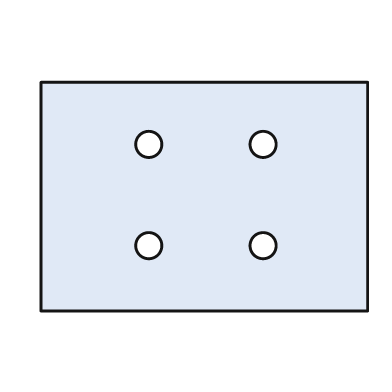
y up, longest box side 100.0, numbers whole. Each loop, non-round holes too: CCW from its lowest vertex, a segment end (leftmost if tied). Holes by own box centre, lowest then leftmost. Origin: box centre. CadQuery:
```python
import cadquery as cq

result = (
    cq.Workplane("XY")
    .moveTo(-50.0, -35.0)
    .lineTo(50.0, -35.0)
    .lineTo(50.0, 35.0)
    .lineTo(-50.0, 35.0)
    .close()
    .moveTo(-17.0, -15.0)
    .circle(4.0)
    .moveTo(18.0, -15.0)
    .circle(4.0)
    .moveTo(-17.0, 16.0)
    .circle(4.0)
    .moveTo(18.0, 16.0)
    .circle(4.0)
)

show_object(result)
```